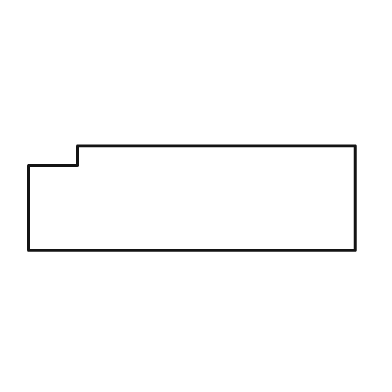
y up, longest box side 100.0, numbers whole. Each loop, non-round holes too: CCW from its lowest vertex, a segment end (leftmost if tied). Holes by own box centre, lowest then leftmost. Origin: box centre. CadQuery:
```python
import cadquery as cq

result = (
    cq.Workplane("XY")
    .moveTo(-50.0, -16.0)
    .lineTo(50.0, -16.0)
    .lineTo(50.0, 16.0)
    .lineTo(-35.0, 16.0)
    .lineTo(-35.0, 10.0)
    .lineTo(-50.0, 10.0)
    .close()
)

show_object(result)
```